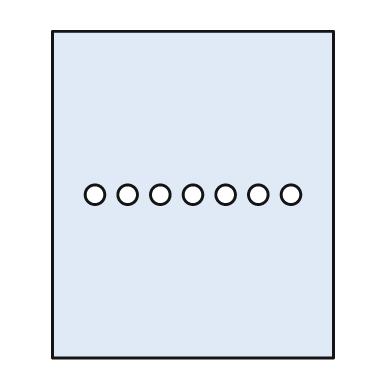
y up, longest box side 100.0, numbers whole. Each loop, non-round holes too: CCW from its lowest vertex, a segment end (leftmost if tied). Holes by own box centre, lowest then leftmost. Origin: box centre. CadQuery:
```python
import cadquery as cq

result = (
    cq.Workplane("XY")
    .moveTo(-43.0, -50.0)
    .lineTo(43.0, -50.0)
    .lineTo(43.0, 50.0)
    .lineTo(-43.0, 50.0)
    .close()
    .moveTo(-30.0, 0.0)
    .circle(3.0)
    .moveTo(-20.0, 0.0)
    .circle(3.0)
    .moveTo(-10.0, 0.0)
    .circle(3.0)
    .moveTo(0.0, 0.0)
    .circle(3.0)
    .moveTo(10.0, 0.0)
    .circle(3.0)
    .moveTo(20.0, 0.0)
    .circle(3.0)
    .moveTo(30.0, 0.0)
    .circle(3.0)
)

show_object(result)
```